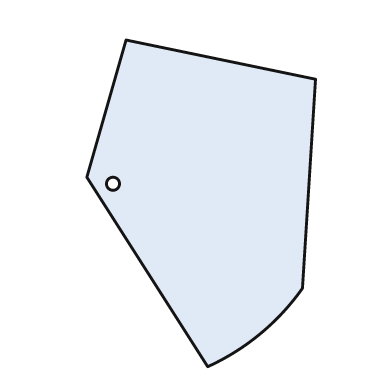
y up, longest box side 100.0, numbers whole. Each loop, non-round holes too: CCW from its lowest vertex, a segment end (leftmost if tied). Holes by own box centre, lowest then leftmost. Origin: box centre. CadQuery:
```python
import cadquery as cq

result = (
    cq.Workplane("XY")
    .moveTo(2.0, -50.0)
    .threePointArc((18.0, -40.0), (31.0, -26.0))
    .lineTo(35.0, 38.0)
    .lineTo(-23.0, 50.0)
    .lineTo(-35.0, 8.0)
    .close()
    .moveTo(-27.0, 6.0)
    .circle(2.0)
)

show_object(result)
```